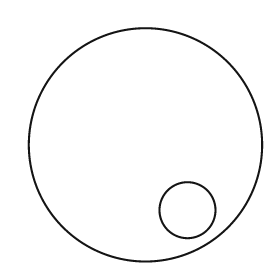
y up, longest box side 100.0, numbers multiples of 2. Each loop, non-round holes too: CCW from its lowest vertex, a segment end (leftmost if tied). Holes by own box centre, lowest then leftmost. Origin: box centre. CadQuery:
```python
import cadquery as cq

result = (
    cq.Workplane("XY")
    .moveTo(0.0, 0.0)
    .circle(50.0)
    .moveTo(18.0, -28.0)
    .circle(12.0)
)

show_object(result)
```